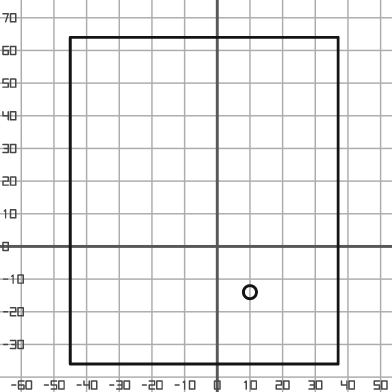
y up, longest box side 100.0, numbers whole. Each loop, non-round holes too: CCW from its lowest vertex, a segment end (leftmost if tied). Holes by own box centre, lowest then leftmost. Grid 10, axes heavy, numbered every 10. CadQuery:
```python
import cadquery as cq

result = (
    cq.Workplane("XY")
    .moveTo(-45.0, -36.0)
    .lineTo(37.0, -36.0)
    .lineTo(37.0, 64.0)
    .lineTo(-45.0, 64.0)
    .close()
    .moveTo(10.0, -14.0)
    .circle(2.0)
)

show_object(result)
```